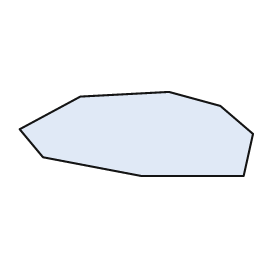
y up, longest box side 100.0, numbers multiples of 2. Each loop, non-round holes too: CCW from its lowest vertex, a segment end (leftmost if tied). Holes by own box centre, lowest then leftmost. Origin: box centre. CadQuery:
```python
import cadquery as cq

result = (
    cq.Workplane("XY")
    .moveTo(2.0, -18.0)
    .lineTo(46.0, -18.0)
    .lineTo(50.0, 0.0)
    .lineTo(36.0, 12.0)
    .lineTo(14.0, 18.0)
    .lineTo(-24.0, 16.0)
    .lineTo(-50.0, 2.0)
    .lineTo(-40.0, -10.0)
    .close()
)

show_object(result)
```